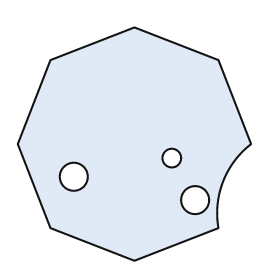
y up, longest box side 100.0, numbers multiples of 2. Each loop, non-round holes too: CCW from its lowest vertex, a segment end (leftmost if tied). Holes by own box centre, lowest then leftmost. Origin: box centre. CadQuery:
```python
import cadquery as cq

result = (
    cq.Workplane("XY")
    .moveTo(0.0, -50.0)
    .lineTo(36.0, -36.0)
    .threePointArc((38.0, -16.0), (50.0, 0.0))
    .lineTo(36.0, 36.0)
    .lineTo(0.0, 50.0)
    .lineTo(-36.0, 36.0)
    .lineTo(-50.0, 0.0)
    .lineTo(-36.0, -36.0)
    .close()
    .moveTo(26.0, -24.0)
    .circle(6.0)
    .moveTo(-26.0, -14.0)
    .circle(6.0)
    .moveTo(16.0, -6.0)
    .circle(4.0)
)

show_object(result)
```